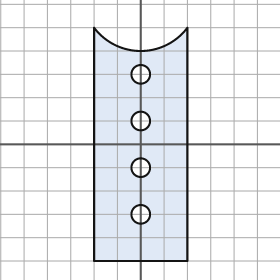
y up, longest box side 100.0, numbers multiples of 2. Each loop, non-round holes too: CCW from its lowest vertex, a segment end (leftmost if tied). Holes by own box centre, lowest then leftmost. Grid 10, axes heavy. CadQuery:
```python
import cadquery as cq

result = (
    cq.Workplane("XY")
    .moveTo(-20.0, -50.0)
    .lineTo(20.0, -50.0)
    .lineTo(20.0, 50.0)
    .threePointArc((0.0, 40.0), (-20.0, 50.0))
    .close()
    .moveTo(0.0, -30.0)
    .circle(4.0)
    .moveTo(0.0, -10.0)
    .circle(4.0)
    .moveTo(0.0, 10.0)
    .circle(4.0)
    .moveTo(0.0, 30.0)
    .circle(4.0)
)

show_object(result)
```